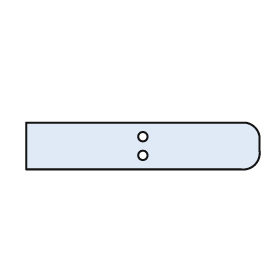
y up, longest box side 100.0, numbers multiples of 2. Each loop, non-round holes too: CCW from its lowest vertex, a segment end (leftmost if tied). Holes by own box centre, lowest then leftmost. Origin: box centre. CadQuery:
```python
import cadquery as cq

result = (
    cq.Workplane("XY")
    .moveTo(-50.0, -10.0)
    .lineTo(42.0, -10.0)
    .threePointArc((48.0, -8.0), (50.0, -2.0))
    .lineTo(50.0, 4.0)
    .threePointArc((48.0, 8.0), (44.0, 10.0))
    .lineTo(-50.0, 10.0)
    .close()
    .moveTo(0.0, -4.0)
    .circle(2.0)
    .moveTo(0.0, 4.0)
    .circle(2.0)
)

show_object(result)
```